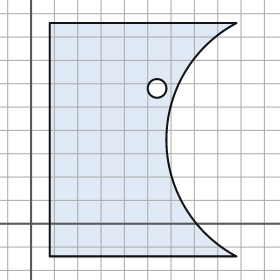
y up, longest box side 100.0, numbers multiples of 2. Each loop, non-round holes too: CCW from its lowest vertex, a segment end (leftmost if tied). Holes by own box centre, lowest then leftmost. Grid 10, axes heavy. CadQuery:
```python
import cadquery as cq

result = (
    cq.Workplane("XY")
    .moveTo(8.0, -14.0)
    .lineTo(88.0, -14.0)
    .threePointArc((58.0, 36.0), (88.0, 86.0))
    .lineTo(8.0, 86.0)
    .close()
    .moveTo(54.0, 58.0)
    .circle(4.0)
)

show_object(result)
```